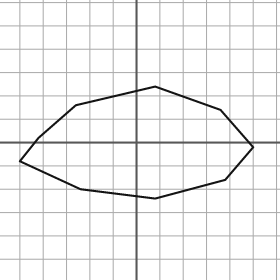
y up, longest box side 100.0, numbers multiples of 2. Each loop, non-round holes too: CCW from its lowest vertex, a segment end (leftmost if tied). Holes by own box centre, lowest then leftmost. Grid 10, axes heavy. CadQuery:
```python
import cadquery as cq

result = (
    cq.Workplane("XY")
    .moveTo(8.0, -24.0)
    .lineTo(38.0, -16.0)
    .lineTo(50.0, -2.0)
    .lineTo(36.0, 14.0)
    .lineTo(8.0, 24.0)
    .lineTo(-26.0, 16.0)
    .lineTo(-42.0, 2.0)
    .lineTo(-50.0, -8.0)
    .lineTo(-24.0, -20.0)
    .close()
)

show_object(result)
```